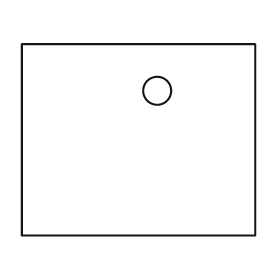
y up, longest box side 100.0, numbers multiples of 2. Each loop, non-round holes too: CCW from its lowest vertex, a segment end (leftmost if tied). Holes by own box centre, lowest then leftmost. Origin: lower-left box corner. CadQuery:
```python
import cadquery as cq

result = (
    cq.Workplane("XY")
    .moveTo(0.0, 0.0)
    .lineTo(100.0, 0.0)
    .lineTo(100.0, 82.0)
    .lineTo(0.0, 82.0)
    .close()
    .moveTo(58.0, 62.0)
    .circle(6.0)
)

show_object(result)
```